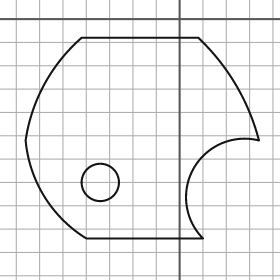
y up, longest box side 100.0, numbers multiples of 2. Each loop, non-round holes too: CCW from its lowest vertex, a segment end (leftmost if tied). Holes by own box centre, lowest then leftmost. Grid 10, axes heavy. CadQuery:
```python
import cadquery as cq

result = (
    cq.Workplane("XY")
    .moveTo(-40.0, -94.0)
    .lineTo(10.0, -94.0)
    .threePointArc((6.0, -64.0), (34.0, -52.0))
    .threePointArc((24.0, -28.0), (8.0, -8.0))
    .lineTo(-42.0, -8.0)
    .threePointArc((-58.0, -28.0), (-66.0, -52.0))
    .threePointArc((-58.0, -76.0), (-40.0, -94.0))
    .close()
    .moveTo(-34.0, -70.0)
    .circle(8.0)
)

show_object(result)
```